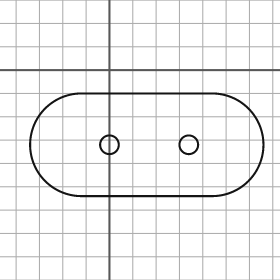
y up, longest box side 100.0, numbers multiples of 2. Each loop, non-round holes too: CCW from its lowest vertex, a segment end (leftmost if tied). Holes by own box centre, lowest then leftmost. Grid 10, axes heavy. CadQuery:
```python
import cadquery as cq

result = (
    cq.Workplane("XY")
    .moveTo(-12.0, -54.0)
    .lineTo(44.0, -54.0)
    .threePointArc((66.0, -32.0), (44.0, -10.0))
    .lineTo(-12.0, -10.0)
    .threePointArc((-34.0, -32.0), (-12.0, -54.0))
    .close()
    .moveTo(0.0, -32.0)
    .circle(4.0)
    .moveTo(34.0, -32.0)
    .circle(4.0)
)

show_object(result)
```